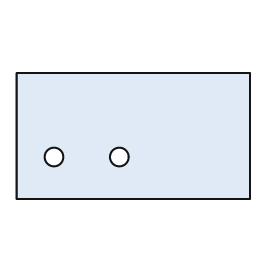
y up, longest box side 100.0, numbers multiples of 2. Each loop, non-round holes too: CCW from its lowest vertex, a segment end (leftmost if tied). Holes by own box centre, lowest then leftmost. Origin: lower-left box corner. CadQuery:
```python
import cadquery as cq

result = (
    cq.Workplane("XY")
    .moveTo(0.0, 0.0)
    .lineTo(100.0, 0.0)
    .lineTo(100.0, 54.0)
    .lineTo(0.0, 54.0)
    .close()
    .moveTo(16.0, 18.0)
    .circle(4.0)
    .moveTo(44.0, 18.0)
    .circle(4.0)
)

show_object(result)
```